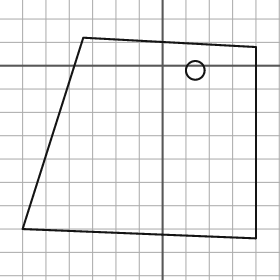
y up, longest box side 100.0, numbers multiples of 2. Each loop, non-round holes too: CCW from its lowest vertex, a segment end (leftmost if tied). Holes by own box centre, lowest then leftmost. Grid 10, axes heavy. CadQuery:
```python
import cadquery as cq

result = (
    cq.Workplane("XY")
    .moveTo(40.0, -74.0)
    .lineTo(40.0, 8.0)
    .lineTo(-34.0, 12.0)
    .lineTo(-60.0, -70.0)
    .close()
    .moveTo(14.0, -2.0)
    .circle(4.0)
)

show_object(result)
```